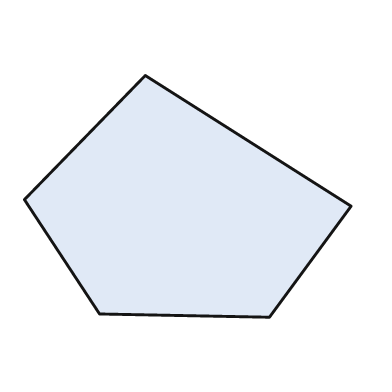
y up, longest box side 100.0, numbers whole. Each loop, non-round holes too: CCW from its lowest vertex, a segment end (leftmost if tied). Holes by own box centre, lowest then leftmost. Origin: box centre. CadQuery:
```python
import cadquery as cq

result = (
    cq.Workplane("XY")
    .moveTo(25.0, -37.0)
    .lineTo(50.0, -3.0)
    .lineTo(-13.0, 37.0)
    .lineTo(-50.0, -1.0)
    .lineTo(-27.0, -36.0)
    .close()
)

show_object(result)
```